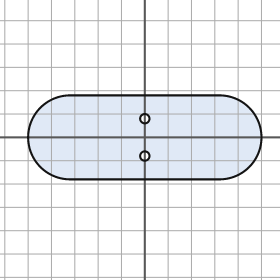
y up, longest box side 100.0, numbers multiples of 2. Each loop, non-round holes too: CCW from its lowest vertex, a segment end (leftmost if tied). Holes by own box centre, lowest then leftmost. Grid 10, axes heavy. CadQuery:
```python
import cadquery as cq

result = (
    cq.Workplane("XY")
    .moveTo(-32.0, -18.0)
    .lineTo(32.0, -18.0)
    .threePointArc((50.0, 0.0), (32.0, 18.0))
    .lineTo(-32.0, 18.0)
    .threePointArc((-50.0, 0.0), (-32.0, -18.0))
    .close()
    .moveTo(0.0, -8.0)
    .circle(2.0)
    .moveTo(0.0, 8.0)
    .circle(2.0)
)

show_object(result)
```